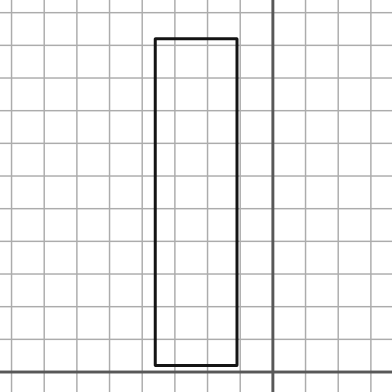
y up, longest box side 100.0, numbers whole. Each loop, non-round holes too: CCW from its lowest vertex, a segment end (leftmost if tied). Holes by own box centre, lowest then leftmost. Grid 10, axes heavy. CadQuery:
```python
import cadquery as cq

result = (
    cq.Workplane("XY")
    .moveTo(-36.0, 2.0)
    .lineTo(-11.0, 2.0)
    .lineTo(-11.0, 102.0)
    .lineTo(-36.0, 102.0)
    .close()
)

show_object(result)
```